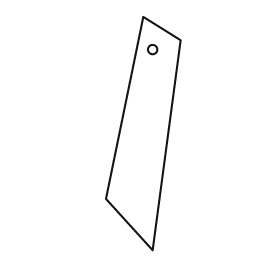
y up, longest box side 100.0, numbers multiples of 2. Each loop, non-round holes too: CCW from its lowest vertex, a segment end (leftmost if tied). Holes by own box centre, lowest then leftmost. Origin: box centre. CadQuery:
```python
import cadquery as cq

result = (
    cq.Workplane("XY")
    .moveTo(4.0, -50.0)
    .lineTo(16.0, 40.0)
    .lineTo(0.0, 50.0)
    .lineTo(-16.0, -28.0)
    .close()
    .moveTo(4.0, 36.0)
    .circle(2.0)
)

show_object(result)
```